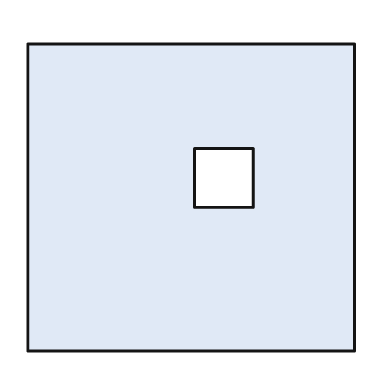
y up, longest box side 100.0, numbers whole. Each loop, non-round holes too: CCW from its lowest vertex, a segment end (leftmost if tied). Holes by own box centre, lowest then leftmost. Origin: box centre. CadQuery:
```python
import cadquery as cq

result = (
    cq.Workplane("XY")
    .moveTo(-50.0, -47.0)
    .lineTo(50.0, -47.0)
    .lineTo(50.0, 47.0)
    .lineTo(-50.0, 47.0)
    .close()
    .moveTo(1.0, -3.0)
    .lineTo(19.0, -3.0)
    .lineTo(19.0, 15.0)
    .lineTo(1.0, 15.0)
    .close()
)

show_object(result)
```